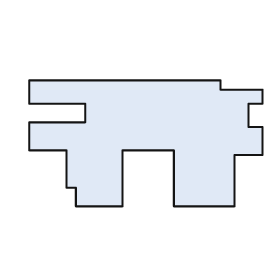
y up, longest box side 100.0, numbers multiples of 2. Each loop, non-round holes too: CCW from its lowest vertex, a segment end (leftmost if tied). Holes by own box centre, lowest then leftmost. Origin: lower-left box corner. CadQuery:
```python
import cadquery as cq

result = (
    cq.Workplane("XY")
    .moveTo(20.0, 0.0)
    .lineTo(40.0, 0.0)
    .lineTo(40.0, 24.0)
    .lineTo(62.0, 24.0)
    .lineTo(62.0, 0.0)
    .lineTo(88.0, 0.0)
    .lineTo(88.0, 22.0)
    .lineTo(100.0, 22.0)
    .lineTo(100.0, 34.0)
    .lineTo(94.0, 34.0)
    .lineTo(94.0, 44.0)
    .lineTo(100.0, 44.0)
    .lineTo(100.0, 50.0)
    .lineTo(82.0, 50.0)
    .lineTo(82.0, 54.0)
    .lineTo(0.0, 54.0)
    .lineTo(0.0, 44.0)
    .lineTo(24.0, 44.0)
    .lineTo(24.0, 36.0)
    .lineTo(0.0, 36.0)
    .lineTo(0.0, 24.0)
    .lineTo(16.0, 24.0)
    .lineTo(16.0, 8.0)
    .lineTo(20.0, 8.0)
    .close()
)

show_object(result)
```